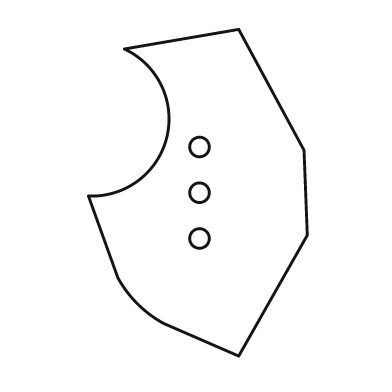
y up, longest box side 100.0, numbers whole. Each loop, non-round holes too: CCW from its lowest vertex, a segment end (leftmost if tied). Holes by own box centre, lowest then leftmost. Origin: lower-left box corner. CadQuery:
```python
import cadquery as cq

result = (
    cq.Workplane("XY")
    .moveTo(46.0, 0.0)
    .lineTo(67.0, 37.0)
    .lineTo(66.0, 63.0)
    .lineTo(46.0, 100.0)
    .lineTo(11.0, 94.0)
    .threePointArc((24.0, 67.0), (0.0, 49.0))
    .lineTo(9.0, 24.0)
    .threePointArc((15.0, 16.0), (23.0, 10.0))
    .close()
    .moveTo(34.0, 36.0)
    .circle(3.0)
    .moveTo(34.0, 50.0)
    .circle(3.0)
    .moveTo(34.0, 64.0)
    .circle(3.0)
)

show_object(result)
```